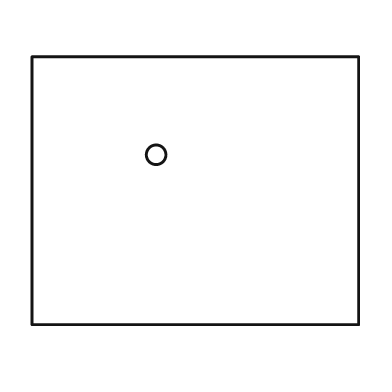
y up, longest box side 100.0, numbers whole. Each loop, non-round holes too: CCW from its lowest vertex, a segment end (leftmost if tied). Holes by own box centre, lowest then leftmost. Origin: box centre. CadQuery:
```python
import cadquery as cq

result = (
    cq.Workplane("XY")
    .moveTo(-50.0, -41.0)
    .lineTo(50.0, -41.0)
    .lineTo(50.0, 41.0)
    .lineTo(-50.0, 41.0)
    .close()
    .moveTo(-12.0, 11.0)
    .circle(3.0)
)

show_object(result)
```